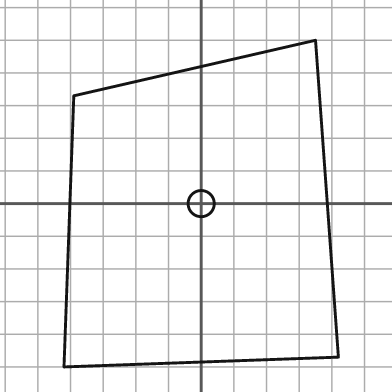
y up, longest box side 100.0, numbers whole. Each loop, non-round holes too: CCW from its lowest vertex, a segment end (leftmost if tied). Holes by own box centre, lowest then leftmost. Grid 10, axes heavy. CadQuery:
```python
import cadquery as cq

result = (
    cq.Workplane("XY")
    .moveTo(-42.0, -50.0)
    .lineTo(42.0, -47.0)
    .lineTo(35.0, 50.0)
    .lineTo(-39.0, 33.0)
    .close()
    .moveTo(0.0, 0.0)
    .circle(4.0)
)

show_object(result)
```